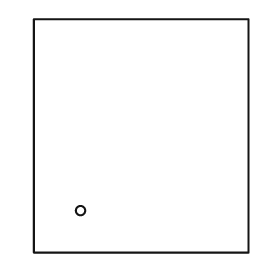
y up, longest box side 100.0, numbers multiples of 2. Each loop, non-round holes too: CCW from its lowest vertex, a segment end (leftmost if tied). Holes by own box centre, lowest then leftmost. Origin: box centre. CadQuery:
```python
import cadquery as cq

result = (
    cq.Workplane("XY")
    .moveTo(-46.0, -50.0)
    .lineTo(46.0, -50.0)
    .lineTo(46.0, 50.0)
    .lineTo(-46.0, 50.0)
    .close()
    .moveTo(-26.0, -32.0)
    .circle(2.0)
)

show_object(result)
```